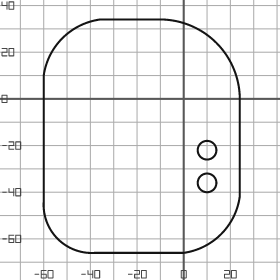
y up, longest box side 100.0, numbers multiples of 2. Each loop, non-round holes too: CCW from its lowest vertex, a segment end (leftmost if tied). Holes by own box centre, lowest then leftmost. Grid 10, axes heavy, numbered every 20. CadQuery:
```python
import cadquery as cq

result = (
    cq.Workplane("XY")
    .moveTo(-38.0, -66.0)
    .lineTo(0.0, -66.0)
    .threePointArc((16.0, -58.0), (24.0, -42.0))
    .lineTo(24.0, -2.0)
    .threePointArc((14.0, 24.0), (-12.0, 34.0))
    .lineTo(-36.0, 34.0)
    .threePointArc((-52.0, 26.0), (-60.0, 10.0))
    .lineTo(-60.0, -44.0)
    .threePointArc((-54.0, -60.0), (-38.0, -66.0))
    .close()
    .moveTo(10.0, -36.0)
    .circle(4.0)
    .moveTo(10.0, -22.0)
    .circle(4.0)
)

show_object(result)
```